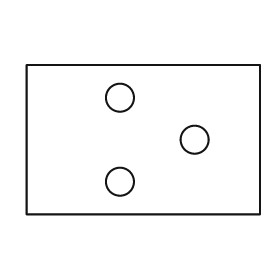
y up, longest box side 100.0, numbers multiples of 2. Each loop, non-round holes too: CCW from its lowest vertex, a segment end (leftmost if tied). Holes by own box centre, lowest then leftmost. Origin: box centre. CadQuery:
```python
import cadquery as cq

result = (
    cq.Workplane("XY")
    .moveTo(-50.0, -32.0)
    .lineTo(50.0, -32.0)
    .lineTo(50.0, 32.0)
    .lineTo(-50.0, 32.0)
    .close()
    .moveTo(-10.0, -18.0)
    .circle(6.0)
    .moveTo(22.0, 0.0)
    .circle(6.0)
    .moveTo(-10.0, 18.0)
    .circle(6.0)
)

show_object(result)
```